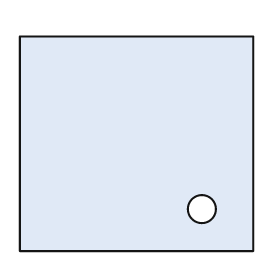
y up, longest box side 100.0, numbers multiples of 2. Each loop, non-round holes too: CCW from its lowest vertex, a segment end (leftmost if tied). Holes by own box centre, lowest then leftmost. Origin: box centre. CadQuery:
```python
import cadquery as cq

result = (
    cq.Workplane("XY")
    .moveTo(-50.0, -46.0)
    .lineTo(50.0, -46.0)
    .lineTo(50.0, 46.0)
    .lineTo(-50.0, 46.0)
    .close()
    .moveTo(28.0, -28.0)
    .circle(6.0)
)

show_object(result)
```